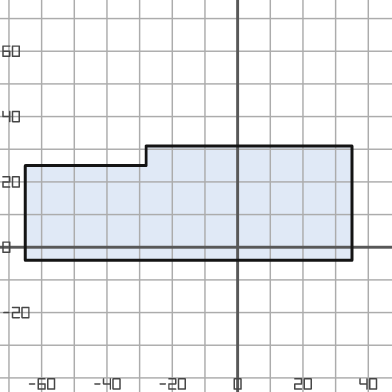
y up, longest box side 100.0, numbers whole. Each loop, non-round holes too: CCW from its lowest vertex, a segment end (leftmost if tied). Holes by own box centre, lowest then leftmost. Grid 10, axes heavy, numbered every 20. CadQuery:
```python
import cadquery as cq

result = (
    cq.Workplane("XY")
    .moveTo(-65.0, -4.0)
    .lineTo(35.0, -4.0)
    .lineTo(35.0, 31.0)
    .lineTo(-28.0, 31.0)
    .lineTo(-28.0, 25.0)
    .lineTo(-65.0, 25.0)
    .close()
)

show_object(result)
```